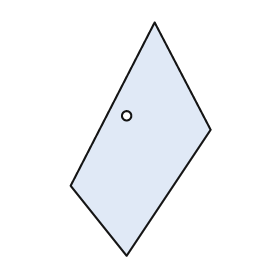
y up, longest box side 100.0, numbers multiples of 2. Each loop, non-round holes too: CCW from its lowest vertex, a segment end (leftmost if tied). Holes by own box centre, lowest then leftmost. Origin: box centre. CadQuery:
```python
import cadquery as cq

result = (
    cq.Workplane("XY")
    .moveTo(-6.0, -50.0)
    .lineTo(30.0, 4.0)
    .lineTo(6.0, 50.0)
    .lineTo(-30.0, -20.0)
    .close()
    .moveTo(-6.0, 10.0)
    .circle(2.0)
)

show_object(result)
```